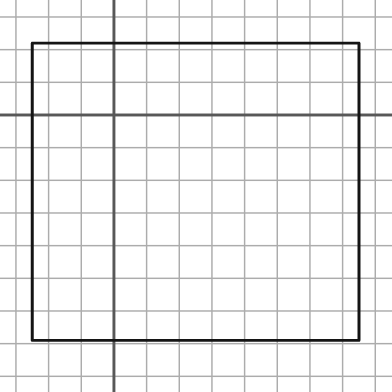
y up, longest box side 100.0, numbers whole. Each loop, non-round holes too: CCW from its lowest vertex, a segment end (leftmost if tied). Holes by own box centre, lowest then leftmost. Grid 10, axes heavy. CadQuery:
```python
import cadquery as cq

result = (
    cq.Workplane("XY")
    .moveTo(-25.0, -69.0)
    .lineTo(75.0, -69.0)
    .lineTo(75.0, 22.0)
    .lineTo(-25.0, 22.0)
    .close()
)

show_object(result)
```